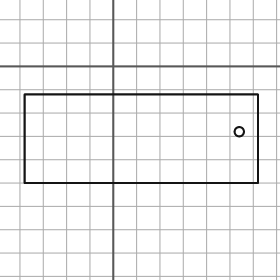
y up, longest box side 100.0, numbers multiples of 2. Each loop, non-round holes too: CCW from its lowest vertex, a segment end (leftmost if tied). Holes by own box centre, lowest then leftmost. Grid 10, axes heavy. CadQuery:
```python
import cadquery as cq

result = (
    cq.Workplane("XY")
    .moveTo(-38.0, -50.0)
    .lineTo(62.0, -50.0)
    .lineTo(62.0, -12.0)
    .lineTo(-38.0, -12.0)
    .close()
    .moveTo(54.0, -28.0)
    .circle(2.0)
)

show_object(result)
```